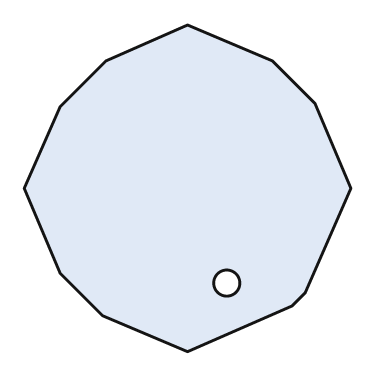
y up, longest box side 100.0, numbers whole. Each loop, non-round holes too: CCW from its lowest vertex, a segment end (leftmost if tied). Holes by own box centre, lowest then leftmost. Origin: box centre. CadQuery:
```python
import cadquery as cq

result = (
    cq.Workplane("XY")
    .moveTo(0.0, -50.0)
    .lineTo(32.0, -36.0)
    .lineTo(36.0, -32.0)
    .lineTo(50.0, 0.0)
    .lineTo(39.0, 26.0)
    .lineTo(26.0, 39.0)
    .lineTo(0.0, 50.0)
    .lineTo(-25.0, 39.0)
    .lineTo(-39.0, 25.0)
    .lineTo(-50.0, 0.0)
    .lineTo(-39.0, -26.0)
    .lineTo(-26.0, -39.0)
    .close()
    .moveTo(12.0, -29.0)
    .circle(4.0)
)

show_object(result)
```